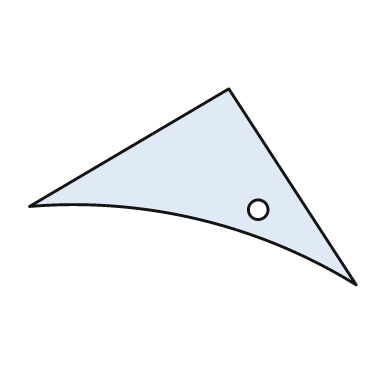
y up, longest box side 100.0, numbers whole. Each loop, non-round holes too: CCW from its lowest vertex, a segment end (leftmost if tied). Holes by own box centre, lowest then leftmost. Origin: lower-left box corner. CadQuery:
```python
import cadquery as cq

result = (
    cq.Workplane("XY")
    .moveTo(100.0, 0.0)
    .lineTo(61.0, 60.0)
    .lineTo(0.0, 24.0)
    .threePointArc((52.0, 20.0), (100.0, 0.0))
    .close()
    .moveTo(70.0, 23.0)
    .circle(3.0)
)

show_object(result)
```